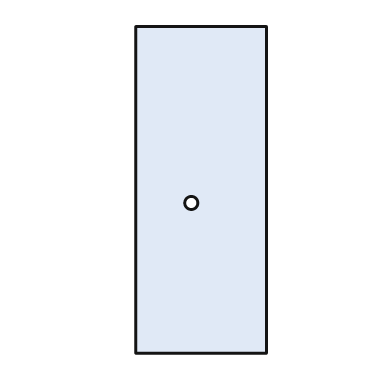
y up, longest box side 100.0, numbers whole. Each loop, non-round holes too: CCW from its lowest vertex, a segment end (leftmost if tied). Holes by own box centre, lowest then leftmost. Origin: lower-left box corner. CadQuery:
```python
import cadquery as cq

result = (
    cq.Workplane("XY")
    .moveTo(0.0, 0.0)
    .lineTo(40.0, 0.0)
    .lineTo(40.0, 100.0)
    .lineTo(0.0, 100.0)
    .close()
    .moveTo(17.0, 46.0)
    .circle(2.0)
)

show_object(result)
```